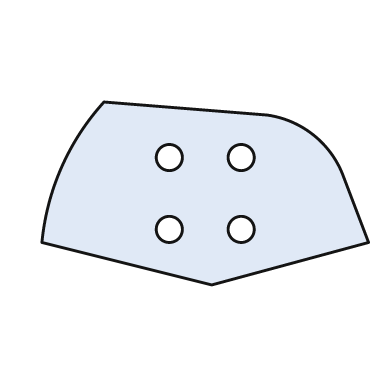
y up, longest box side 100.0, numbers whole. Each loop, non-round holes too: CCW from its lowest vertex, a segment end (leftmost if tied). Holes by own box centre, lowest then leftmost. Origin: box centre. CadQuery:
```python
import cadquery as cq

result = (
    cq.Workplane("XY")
    .moveTo(2.0, -28.0)
    .lineTo(50.0, -15.0)
    .lineTo(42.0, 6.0)
    .threePointArc((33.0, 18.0), (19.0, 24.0))
    .lineTo(-31.0, 28.0)
    .threePointArc((-44.0, 8.0), (-50.0, -15.0))
    .close()
    .moveTo(-11.0, -11.0)
    .circle(4.0)
    .moveTo(11.0, -11.0)
    .circle(4.0)
    .moveTo(-11.0, 11.0)
    .circle(4.0)
    .moveTo(11.0, 11.0)
    .circle(4.0)
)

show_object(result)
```